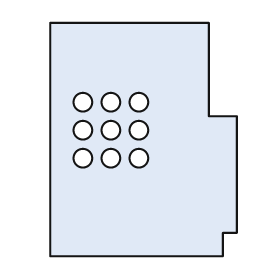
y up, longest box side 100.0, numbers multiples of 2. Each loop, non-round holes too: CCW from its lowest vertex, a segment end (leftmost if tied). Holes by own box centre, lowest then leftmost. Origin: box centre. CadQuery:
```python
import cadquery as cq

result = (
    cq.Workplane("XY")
    .moveTo(-40.0, -50.0)
    .lineTo(34.0, -50.0)
    .lineTo(34.0, -40.0)
    .lineTo(40.0, -40.0)
    .lineTo(40.0, 10.0)
    .lineTo(28.0, 10.0)
    .lineTo(28.0, 50.0)
    .lineTo(-40.0, 50.0)
    .close()
    .moveTo(-26.0, -8.0)
    .circle(4.0)
    .moveTo(-14.0, -8.0)
    .circle(4.0)
    .moveTo(-2.0, -8.0)
    .circle(4.0)
    .moveTo(-26.0, 4.0)
    .circle(4.0)
    .moveTo(-14.0, 4.0)
    .circle(4.0)
    .moveTo(-2.0, 4.0)
    .circle(4.0)
    .moveTo(-26.0, 16.0)
    .circle(4.0)
    .moveTo(-14.0, 16.0)
    .circle(4.0)
    .moveTo(-2.0, 16.0)
    .circle(4.0)
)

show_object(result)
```